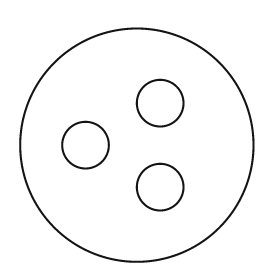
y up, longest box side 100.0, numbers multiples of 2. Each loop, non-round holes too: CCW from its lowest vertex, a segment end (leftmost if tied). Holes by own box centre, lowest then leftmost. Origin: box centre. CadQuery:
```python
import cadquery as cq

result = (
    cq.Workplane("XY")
    .moveTo(0.0, 0.0)
    .circle(50.0)
    .moveTo(10.0, -18.0)
    .circle(10.0)
    .moveTo(-22.0, 0.0)
    .circle(10.0)
    .moveTo(10.0, 18.0)
    .circle(10.0)
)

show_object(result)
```